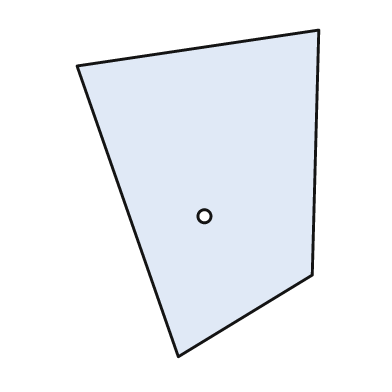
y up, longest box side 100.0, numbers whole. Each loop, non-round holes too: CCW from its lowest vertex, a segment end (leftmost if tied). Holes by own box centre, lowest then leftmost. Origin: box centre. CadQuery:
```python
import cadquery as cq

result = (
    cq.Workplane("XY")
    .moveTo(-6.0, -50.0)
    .lineTo(35.0, -25.0)
    .lineTo(37.0, 50.0)
    .lineTo(-37.0, 39.0)
    .close()
    .moveTo(2.0, -7.0)
    .circle(2.0)
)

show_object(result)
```